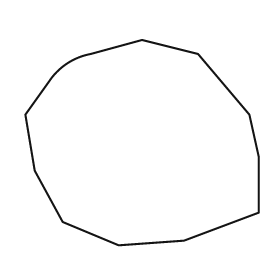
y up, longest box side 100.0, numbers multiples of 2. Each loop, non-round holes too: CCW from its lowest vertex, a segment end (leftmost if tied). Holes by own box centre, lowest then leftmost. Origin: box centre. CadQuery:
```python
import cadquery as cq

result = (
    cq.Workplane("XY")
    .moveTo(-10.0, -44.0)
    .lineTo(18.0, -42.0)
    .lineTo(50.0, -30.0)
    .lineTo(50.0, -6.0)
    .lineTo(46.0, 12.0)
    .lineTo(24.0, 38.0)
    .lineTo(0.0, 44.0)
    .lineTo(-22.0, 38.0)
    .threePointArc((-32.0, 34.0), (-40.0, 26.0))
    .lineTo(-50.0, 12.0)
    .lineTo(-46.0, -12.0)
    .lineTo(-34.0, -34.0)
    .close()
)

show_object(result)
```